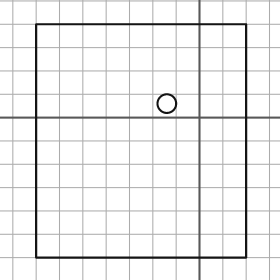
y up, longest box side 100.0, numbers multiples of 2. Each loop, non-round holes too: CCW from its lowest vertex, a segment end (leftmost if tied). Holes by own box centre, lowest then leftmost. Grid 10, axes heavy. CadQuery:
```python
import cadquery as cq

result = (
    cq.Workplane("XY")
    .moveTo(-70.0, -60.0)
    .lineTo(20.0, -60.0)
    .lineTo(20.0, 40.0)
    .lineTo(-70.0, 40.0)
    .close()
    .moveTo(-14.0, 6.0)
    .circle(4.0)
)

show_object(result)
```